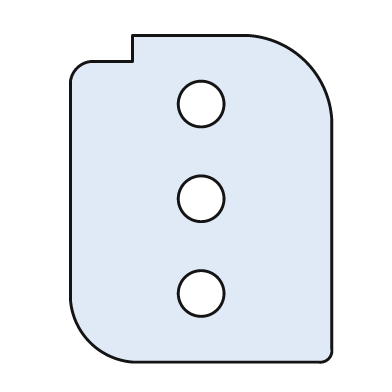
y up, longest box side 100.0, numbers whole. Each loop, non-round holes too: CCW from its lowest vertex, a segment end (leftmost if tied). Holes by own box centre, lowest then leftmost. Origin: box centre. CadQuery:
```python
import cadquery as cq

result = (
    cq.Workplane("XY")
    .moveTo(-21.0, -50.0)
    .lineTo(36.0, -50.0)
    .threePointArc((39.0, -49.0), (40.0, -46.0))
    .lineTo(40.0, 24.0)
    .threePointArc((32.0, 42.0), (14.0, 50.0))
    .lineTo(-21.0, 50.0)
    .lineTo(-21.0, 42.0)
    .lineTo(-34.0, 42.0)
    .threePointArc((-38.0, 40.0), (-40.0, 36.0))
    .lineTo(-40.0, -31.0)
    .threePointArc((-34.0, -44.0), (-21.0, -50.0))
    .close()
    .moveTo(0.0, -29.0)
    .circle(7.0)
    .moveTo(0.0, 0.0)
    .circle(7.0)
    .moveTo(0.0, 29.0)
    .circle(7.0)
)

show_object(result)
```